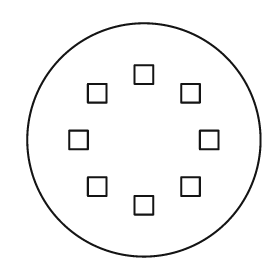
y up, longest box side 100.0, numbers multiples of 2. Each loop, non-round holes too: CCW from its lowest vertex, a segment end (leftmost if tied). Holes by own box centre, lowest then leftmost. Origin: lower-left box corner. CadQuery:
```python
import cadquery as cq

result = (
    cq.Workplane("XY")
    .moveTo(50.0, 50.0)
    .circle(50.0)
    .moveTo(46.0, 18.0)
    .lineTo(54.0, 18.0)
    .lineTo(54.0, 26.0)
    .lineTo(46.0, 26.0)
    .close()
    .moveTo(26.0, 26.0)
    .lineTo(34.0, 26.0)
    .lineTo(34.0, 34.0)
    .lineTo(26.0, 34.0)
    .close()
    .moveTo(66.0, 26.0)
    .lineTo(74.0, 26.0)
    .lineTo(74.0, 34.0)
    .lineTo(66.0, 34.0)
    .close()
    .moveTo(18.0, 46.0)
    .lineTo(26.0, 46.0)
    .lineTo(26.0, 54.0)
    .lineTo(18.0, 54.0)
    .close()
    .moveTo(74.0, 46.0)
    .lineTo(82.0, 46.0)
    .lineTo(82.0, 54.0)
    .lineTo(74.0, 54.0)
    .close()
    .moveTo(26.0, 66.0)
    .lineTo(34.0, 66.0)
    .lineTo(34.0, 74.0)
    .lineTo(26.0, 74.0)
    .close()
    .moveTo(66.0, 66.0)
    .lineTo(74.0, 66.0)
    .lineTo(74.0, 74.0)
    .lineTo(66.0, 74.0)
    .close()
    .moveTo(46.0, 74.0)
    .lineTo(54.0, 74.0)
    .lineTo(54.0, 82.0)
    .lineTo(46.0, 82.0)
    .close()
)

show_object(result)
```